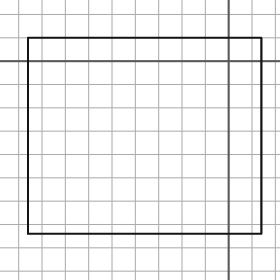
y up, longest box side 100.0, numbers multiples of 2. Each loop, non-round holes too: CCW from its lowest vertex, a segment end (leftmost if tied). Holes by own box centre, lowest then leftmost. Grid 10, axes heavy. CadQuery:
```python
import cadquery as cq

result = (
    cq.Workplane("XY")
    .moveTo(-86.0, -74.0)
    .lineTo(14.0, -74.0)
    .lineTo(14.0, 10.0)
    .lineTo(-86.0, 10.0)
    .close()
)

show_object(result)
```